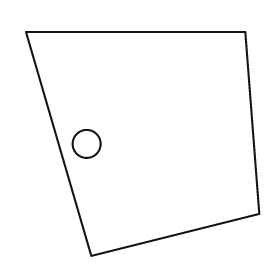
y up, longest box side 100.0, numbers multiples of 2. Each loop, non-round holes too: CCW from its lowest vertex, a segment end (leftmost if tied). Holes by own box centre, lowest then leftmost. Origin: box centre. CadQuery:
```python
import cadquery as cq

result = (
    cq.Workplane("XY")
    .moveTo(-22.0, -48.0)
    .lineTo(50.0, -30.0)
    .lineTo(44.0, 48.0)
    .lineTo(-50.0, 48.0)
    .close()
    .moveTo(-24.0, 0.0)
    .circle(6.0)
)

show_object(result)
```